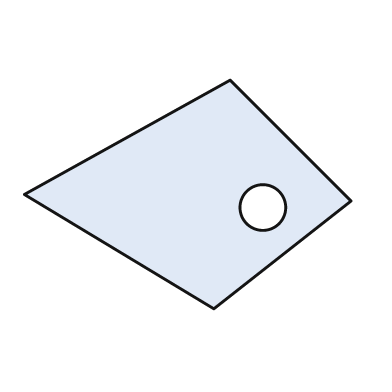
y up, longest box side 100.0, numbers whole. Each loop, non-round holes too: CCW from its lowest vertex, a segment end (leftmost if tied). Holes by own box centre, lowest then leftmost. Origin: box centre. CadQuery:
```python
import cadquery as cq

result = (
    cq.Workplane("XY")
    .moveTo(8.0, -35.0)
    .lineTo(50.0, -2.0)
    .lineTo(13.0, 35.0)
    .lineTo(-50.0, 0.0)
    .close()
    .moveTo(23.0, -4.0)
    .circle(7.0)
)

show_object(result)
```